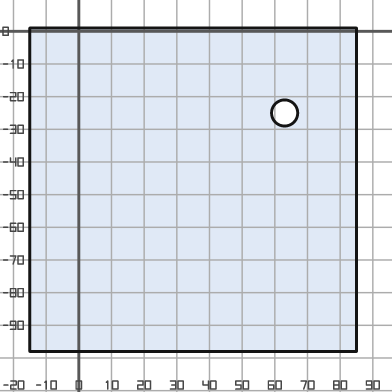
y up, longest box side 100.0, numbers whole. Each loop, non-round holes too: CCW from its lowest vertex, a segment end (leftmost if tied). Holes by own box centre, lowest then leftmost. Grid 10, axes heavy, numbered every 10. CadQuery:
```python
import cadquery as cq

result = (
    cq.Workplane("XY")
    .moveTo(-15.0, -98.0)
    .lineTo(85.0, -98.0)
    .lineTo(85.0, 1.0)
    .lineTo(-15.0, 1.0)
    .close()
    .moveTo(63.0, -25.0)
    .circle(4.0)
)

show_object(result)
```